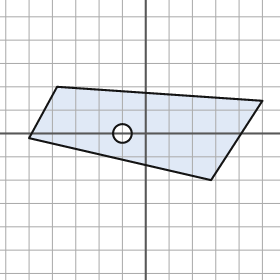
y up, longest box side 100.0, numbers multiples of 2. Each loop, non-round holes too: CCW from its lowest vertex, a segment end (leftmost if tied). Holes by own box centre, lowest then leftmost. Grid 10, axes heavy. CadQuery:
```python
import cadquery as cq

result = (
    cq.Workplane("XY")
    .moveTo(28.0, -20.0)
    .lineTo(50.0, 14.0)
    .lineTo(-38.0, 20.0)
    .lineTo(-50.0, -2.0)
    .close()
    .moveTo(-10.0, 0.0)
    .circle(4.0)
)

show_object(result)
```